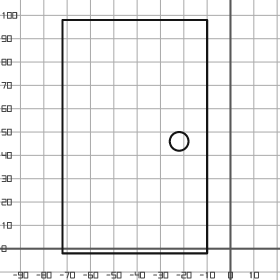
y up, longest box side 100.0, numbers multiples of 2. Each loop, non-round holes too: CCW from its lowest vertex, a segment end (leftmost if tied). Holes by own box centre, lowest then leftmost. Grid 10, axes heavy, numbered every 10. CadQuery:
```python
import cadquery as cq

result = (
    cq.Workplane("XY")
    .moveTo(-72.0, -2.0)
    .lineTo(-10.0, -2.0)
    .lineTo(-10.0, 98.0)
    .lineTo(-72.0, 98.0)
    .close()
    .moveTo(-22.0, 46.0)
    .circle(4.0)
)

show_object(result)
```